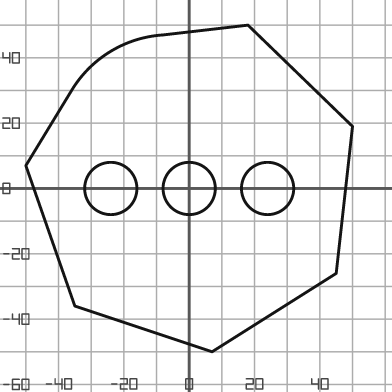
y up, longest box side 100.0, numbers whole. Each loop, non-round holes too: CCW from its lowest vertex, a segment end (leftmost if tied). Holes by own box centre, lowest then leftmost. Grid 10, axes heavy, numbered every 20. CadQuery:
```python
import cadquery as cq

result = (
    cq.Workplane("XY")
    .moveTo(7.0, -50.0)
    .lineTo(45.0, -26.0)
    .lineTo(50.0, 19.0)
    .lineTo(18.0, 50.0)
    .lineTo(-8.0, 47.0)
    .threePointArc((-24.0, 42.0), (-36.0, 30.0))
    .lineTo(-50.0, 7.0)
    .lineTo(-35.0, -36.0)
    .close()
    .moveTo(-24.0, 0.0)
    .circle(8.0)
    .moveTo(0.0, 0.0)
    .circle(8.0)
    .moveTo(24.0, 0.0)
    .circle(8.0)
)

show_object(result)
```